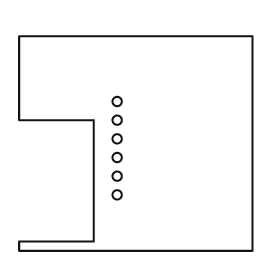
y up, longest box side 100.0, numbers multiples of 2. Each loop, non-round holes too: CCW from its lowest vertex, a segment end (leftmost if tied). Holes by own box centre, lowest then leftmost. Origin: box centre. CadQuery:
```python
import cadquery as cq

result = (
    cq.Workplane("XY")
    .moveTo(-50.0, -46.0)
    .lineTo(50.0, -46.0)
    .lineTo(50.0, 46.0)
    .lineTo(-50.0, 46.0)
    .lineTo(-50.0, 10.0)
    .lineTo(-18.0, 10.0)
    .lineTo(-18.0, -42.0)
    .lineTo(-50.0, -42.0)
    .close()
    .moveTo(-8.0, -22.0)
    .circle(2.0)
    .moveTo(-8.0, -14.0)
    .circle(2.0)
    .moveTo(-8.0, -6.0)
    .circle(2.0)
    .moveTo(-8.0, 2.0)
    .circle(2.0)
    .moveTo(-8.0, 10.0)
    .circle(2.0)
    .moveTo(-8.0, 18.0)
    .circle(2.0)
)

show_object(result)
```